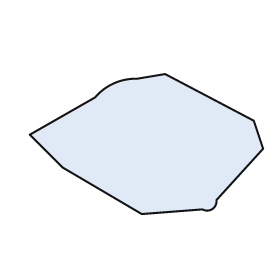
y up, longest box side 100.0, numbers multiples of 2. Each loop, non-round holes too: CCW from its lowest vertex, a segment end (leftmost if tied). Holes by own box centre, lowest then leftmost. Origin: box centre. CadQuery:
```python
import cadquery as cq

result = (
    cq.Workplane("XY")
    .moveTo(-2.0, -30.0)
    .lineTo(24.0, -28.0)
    .threePointArc((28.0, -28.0), (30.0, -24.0))
    .lineTo(50.0, -2.0)
    .lineTo(46.0, 10.0)
    .lineTo(8.0, 30.0)
    .lineTo(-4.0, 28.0)
    .threePointArc((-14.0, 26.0), (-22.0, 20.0))
    .lineTo(-50.0, 4.0)
    .lineTo(-36.0, -10.0)
    .close()
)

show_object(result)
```